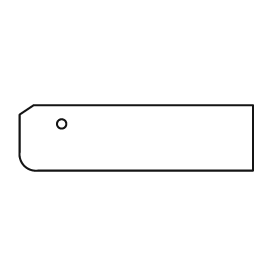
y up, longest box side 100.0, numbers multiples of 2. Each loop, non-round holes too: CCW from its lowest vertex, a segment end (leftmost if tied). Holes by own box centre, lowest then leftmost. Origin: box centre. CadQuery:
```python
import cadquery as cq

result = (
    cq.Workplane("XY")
    .moveTo(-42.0, -14.0)
    .lineTo(50.0, -14.0)
    .lineTo(50.0, 14.0)
    .lineTo(-44.0, 14.0)
    .lineTo(-50.0, 10.0)
    .lineTo(-50.0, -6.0)
    .threePointArc((-48.0, -12.0), (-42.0, -14.0))
    .close()
    .moveTo(-32.0, 6.0)
    .circle(2.0)
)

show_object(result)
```